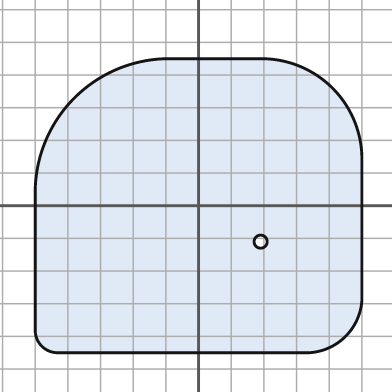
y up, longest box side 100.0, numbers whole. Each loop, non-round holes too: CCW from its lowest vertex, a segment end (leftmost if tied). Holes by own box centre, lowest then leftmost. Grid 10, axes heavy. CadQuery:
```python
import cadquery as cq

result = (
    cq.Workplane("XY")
    .moveTo(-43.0, -45.0)
    .lineTo(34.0, -45.0)
    .threePointArc((45.0, -40.0), (50.0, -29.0))
    .lineTo(50.0, 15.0)
    .threePointArc((41.0, 36.0), (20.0, 45.0))
    .lineTo(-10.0, 45.0)
    .threePointArc((-38.0, 33.0), (-50.0, 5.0))
    .lineTo(-50.0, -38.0)
    .threePointArc((-48.0, -43.0), (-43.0, -45.0))
    .close()
    .moveTo(19.0, -11.0)
    .circle(2.0)
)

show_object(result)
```